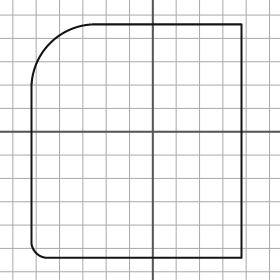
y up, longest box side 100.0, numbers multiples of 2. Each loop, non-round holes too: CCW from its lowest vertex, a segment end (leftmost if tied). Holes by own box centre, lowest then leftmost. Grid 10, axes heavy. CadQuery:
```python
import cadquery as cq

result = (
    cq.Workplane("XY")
    .moveTo(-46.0, -54.0)
    .lineTo(38.0, -54.0)
    .lineTo(38.0, 46.0)
    .lineTo(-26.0, 46.0)
    .threePointArc((-44.0, 38.0), (-52.0, 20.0))
    .lineTo(-52.0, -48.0)
    .threePointArc((-50.0, -52.0), (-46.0, -54.0))
    .close()
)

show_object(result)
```